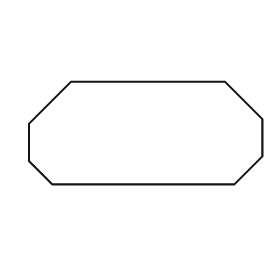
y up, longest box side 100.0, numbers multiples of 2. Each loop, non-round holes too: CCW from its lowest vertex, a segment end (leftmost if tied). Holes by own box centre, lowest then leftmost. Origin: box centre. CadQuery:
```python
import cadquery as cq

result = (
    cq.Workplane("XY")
    .moveTo(-40.0, -22.0)
    .lineTo(38.0, -22.0)
    .lineTo(50.0, -10.0)
    .lineTo(50.0, 6.0)
    .lineTo(34.0, 22.0)
    .lineTo(-32.0, 22.0)
    .lineTo(-50.0, 4.0)
    .lineTo(-50.0, -12.0)
    .close()
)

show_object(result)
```